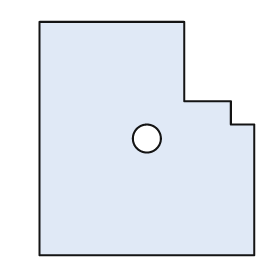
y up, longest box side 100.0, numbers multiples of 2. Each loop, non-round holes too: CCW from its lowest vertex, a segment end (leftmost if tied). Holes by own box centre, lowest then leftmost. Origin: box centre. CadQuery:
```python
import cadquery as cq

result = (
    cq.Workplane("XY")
    .moveTo(-46.0, -50.0)
    .lineTo(46.0, -50.0)
    .lineTo(46.0, 6.0)
    .lineTo(36.0, 6.0)
    .lineTo(36.0, 16.0)
    .lineTo(16.0, 16.0)
    .lineTo(16.0, 50.0)
    .lineTo(-46.0, 50.0)
    .close()
    .moveTo(0.0, 0.0)
    .circle(6.0)
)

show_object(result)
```